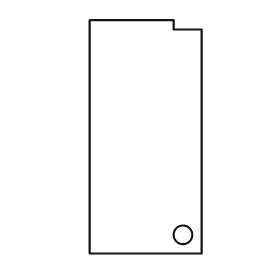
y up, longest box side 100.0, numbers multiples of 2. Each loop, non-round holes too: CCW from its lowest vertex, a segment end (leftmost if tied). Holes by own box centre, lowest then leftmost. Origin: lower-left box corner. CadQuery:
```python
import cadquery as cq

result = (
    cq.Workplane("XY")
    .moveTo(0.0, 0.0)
    .lineTo(48.0, 0.0)
    .lineTo(48.0, 96.0)
    .lineTo(36.0, 96.0)
    .lineTo(36.0, 100.0)
    .lineTo(0.0, 100.0)
    .close()
    .moveTo(40.0, 8.0)
    .circle(4.0)
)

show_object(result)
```